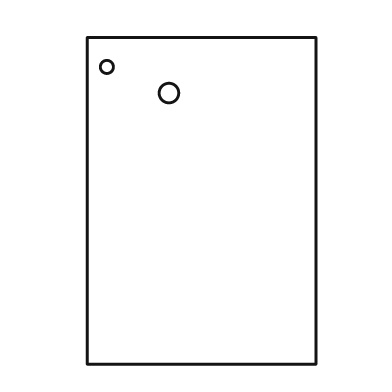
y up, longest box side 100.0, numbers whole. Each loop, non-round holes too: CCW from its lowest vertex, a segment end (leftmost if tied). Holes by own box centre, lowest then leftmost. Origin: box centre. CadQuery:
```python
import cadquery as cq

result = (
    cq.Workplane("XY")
    .moveTo(-35.0, -50.0)
    .lineTo(35.0, -50.0)
    .lineTo(35.0, 50.0)
    .lineTo(-35.0, 50.0)
    .close()
    .moveTo(-10.0, 33.0)
    .circle(3.0)
    .moveTo(-29.0, 41.0)
    .circle(2.0)
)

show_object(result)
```